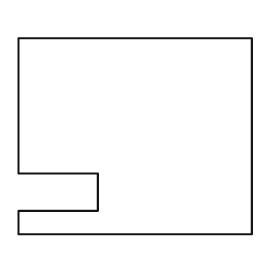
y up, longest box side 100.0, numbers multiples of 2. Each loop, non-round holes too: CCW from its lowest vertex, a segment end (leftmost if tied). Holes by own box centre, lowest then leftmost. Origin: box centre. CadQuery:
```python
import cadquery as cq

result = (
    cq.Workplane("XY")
    .moveTo(-50.0, -42.0)
    .lineTo(50.0, -42.0)
    .lineTo(50.0, 42.0)
    .lineTo(-50.0, 42.0)
    .lineTo(-50.0, -16.0)
    .lineTo(-16.0, -16.0)
    .lineTo(-16.0, -32.0)
    .lineTo(-50.0, -32.0)
    .close()
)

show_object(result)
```